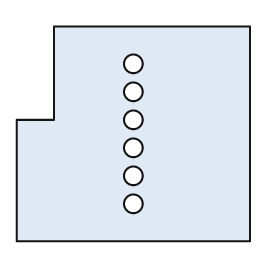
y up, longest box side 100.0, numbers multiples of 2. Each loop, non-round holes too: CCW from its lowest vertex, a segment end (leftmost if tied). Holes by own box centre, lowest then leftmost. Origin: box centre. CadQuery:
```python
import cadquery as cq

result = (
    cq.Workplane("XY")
    .moveTo(-50.0, -46.0)
    .lineTo(50.0, -46.0)
    .lineTo(50.0, 46.0)
    .lineTo(-34.0, 46.0)
    .lineTo(-34.0, 6.0)
    .lineTo(-50.0, 6.0)
    .close()
    .moveTo(0.0, -30.0)
    .circle(4.0)
    .moveTo(0.0, -18.0)
    .circle(4.0)
    .moveTo(0.0, -6.0)
    .circle(4.0)
    .moveTo(0.0, 6.0)
    .circle(4.0)
    .moveTo(0.0, 18.0)
    .circle(4.0)
    .moveTo(0.0, 30.0)
    .circle(4.0)
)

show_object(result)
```